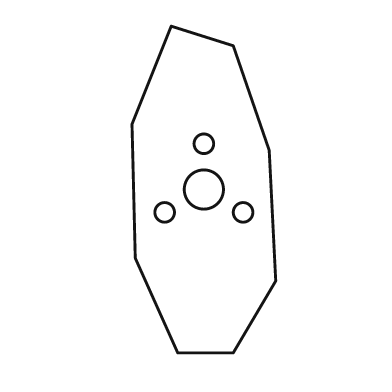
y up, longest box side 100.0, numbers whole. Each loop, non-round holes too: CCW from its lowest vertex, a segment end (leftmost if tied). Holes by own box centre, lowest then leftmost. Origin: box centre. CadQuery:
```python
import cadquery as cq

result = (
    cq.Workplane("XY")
    .moveTo(-8.0, -50.0)
    .lineTo(9.0, -50.0)
    .lineTo(22.0, -28.0)
    .lineTo(20.0, 12.0)
    .lineTo(9.0, 44.0)
    .lineTo(-10.0, 50.0)
    .lineTo(-22.0, 20.0)
    .lineTo(-21.0, -21.0)
    .close()
    .moveTo(-12.0, -7.0)
    .circle(3.0)
    .moveTo(12.0, -7.0)
    .circle(3.0)
    .moveTo(0.0, 0.0)
    .circle(6.0)
    .moveTo(0.0, 14.0)
    .circle(3.0)
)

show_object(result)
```